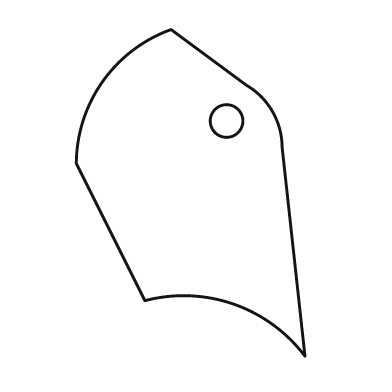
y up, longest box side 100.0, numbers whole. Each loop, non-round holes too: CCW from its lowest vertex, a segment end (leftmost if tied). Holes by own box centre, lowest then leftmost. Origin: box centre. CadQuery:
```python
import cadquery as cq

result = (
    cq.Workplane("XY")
    .moveTo(35.0, -50.0)
    .lineTo(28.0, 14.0)
    .threePointArc((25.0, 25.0), (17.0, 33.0))
    .lineTo(-6.0, 50.0)
    .threePointArc((-27.0, 34.0), (-35.0, 9.0))
    .lineTo(-14.0, -33.0)
    .threePointArc((13.0, -34.0), (35.0, -50.0))
    .close()
    .moveTo(11.0, 22.0)
    .circle(5.0)
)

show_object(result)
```